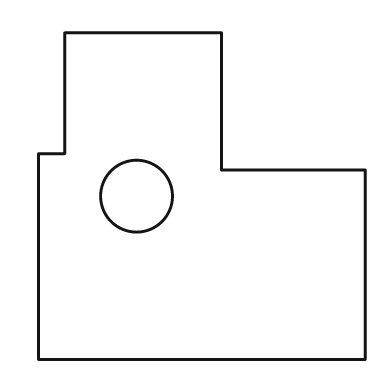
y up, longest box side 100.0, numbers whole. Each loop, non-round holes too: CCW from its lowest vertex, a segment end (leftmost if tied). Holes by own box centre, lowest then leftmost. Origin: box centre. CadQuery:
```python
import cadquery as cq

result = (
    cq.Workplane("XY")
    .moveTo(-50.0, -50.0)
    .lineTo(50.0, -50.0)
    .lineTo(50.0, 8.0)
    .lineTo(6.0, 8.0)
    .lineTo(6.0, 50.0)
    .lineTo(-42.0, 50.0)
    .lineTo(-42.0, 13.0)
    .lineTo(-50.0, 13.0)
    .close()
    .moveTo(-20.0, 0.0)
    .circle(11.0)
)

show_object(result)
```